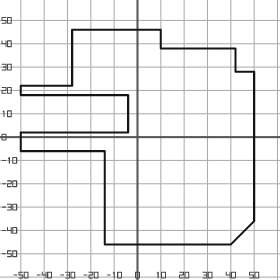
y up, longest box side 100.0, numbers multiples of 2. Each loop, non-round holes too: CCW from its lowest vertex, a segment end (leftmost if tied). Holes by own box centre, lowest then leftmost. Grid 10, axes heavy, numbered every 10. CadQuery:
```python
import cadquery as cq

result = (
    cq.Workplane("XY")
    .moveTo(-14.0, -46.0)
    .lineTo(40.0, -46.0)
    .lineTo(50.0, -36.0)
    .lineTo(50.0, 28.0)
    .lineTo(42.0, 28.0)
    .lineTo(42.0, 38.0)
    .lineTo(10.0, 38.0)
    .lineTo(10.0, 46.0)
    .lineTo(-28.0, 46.0)
    .lineTo(-28.0, 22.0)
    .lineTo(-50.0, 22.0)
    .lineTo(-50.0, 18.0)
    .lineTo(-4.0, 18.0)
    .lineTo(-4.0, 2.0)
    .lineTo(-50.0, 2.0)
    .lineTo(-50.0, -6.0)
    .lineTo(-14.0, -6.0)
    .close()
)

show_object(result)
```